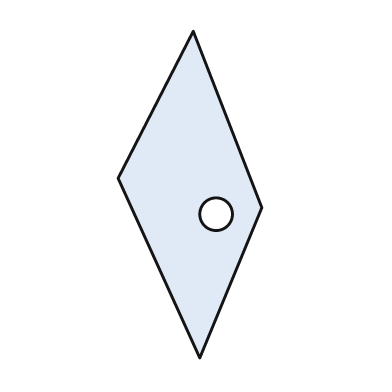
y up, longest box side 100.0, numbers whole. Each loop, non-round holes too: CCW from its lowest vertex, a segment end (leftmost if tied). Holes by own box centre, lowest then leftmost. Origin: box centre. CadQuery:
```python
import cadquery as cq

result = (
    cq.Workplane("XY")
    .moveTo(3.0, -50.0)
    .lineTo(22.0, -4.0)
    .lineTo(1.0, 50.0)
    .lineTo(-22.0, 5.0)
    .close()
    .moveTo(8.0, -6.0)
    .circle(5.0)
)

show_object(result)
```